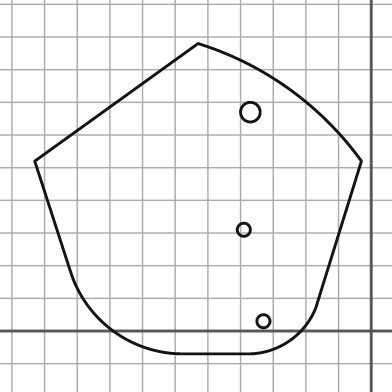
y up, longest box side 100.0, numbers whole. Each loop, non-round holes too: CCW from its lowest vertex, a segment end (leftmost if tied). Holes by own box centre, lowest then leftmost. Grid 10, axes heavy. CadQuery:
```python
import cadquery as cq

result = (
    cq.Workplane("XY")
    .moveTo(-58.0, -7.0)
    .lineTo(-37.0, -7.0)
    .threePointArc((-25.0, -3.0), (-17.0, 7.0))
    .lineTo(-3.0, 52.0)
    .threePointArc((-25.0, 74.0), (-53.0, 88.0))
    .lineTo(-103.0, 52.0)
    .lineTo(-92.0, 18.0)
    .threePointArc((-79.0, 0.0), (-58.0, -7.0))
    .close()
    .moveTo(-33.0, 3.0)
    .circle(2.0)
    .moveTo(-39.0, 31.0)
    .circle(2.0)
    .moveTo(-37.0, 67.0)
    .circle(3.0)
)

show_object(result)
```